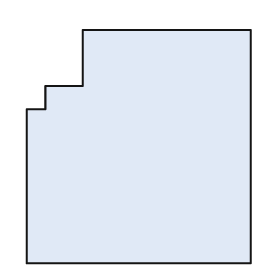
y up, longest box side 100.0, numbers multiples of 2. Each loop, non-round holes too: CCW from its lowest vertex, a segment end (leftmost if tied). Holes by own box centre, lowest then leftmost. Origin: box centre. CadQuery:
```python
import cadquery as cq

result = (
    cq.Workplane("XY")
    .moveTo(-48.0, -50.0)
    .lineTo(48.0, -50.0)
    .lineTo(48.0, 50.0)
    .lineTo(-24.0, 50.0)
    .lineTo(-24.0, 26.0)
    .lineTo(-40.0, 26.0)
    .lineTo(-40.0, 16.0)
    .lineTo(-48.0, 16.0)
    .close()
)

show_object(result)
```